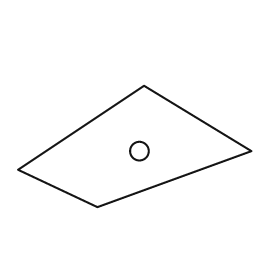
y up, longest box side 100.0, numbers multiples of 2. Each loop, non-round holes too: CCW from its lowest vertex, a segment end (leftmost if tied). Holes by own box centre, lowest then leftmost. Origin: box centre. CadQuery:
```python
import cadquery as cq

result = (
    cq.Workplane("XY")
    .moveTo(-16.0, -26.0)
    .lineTo(50.0, -2.0)
    .lineTo(4.0, 26.0)
    .lineTo(-50.0, -10.0)
    .close()
    .moveTo(2.0, -2.0)
    .circle(4.0)
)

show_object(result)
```